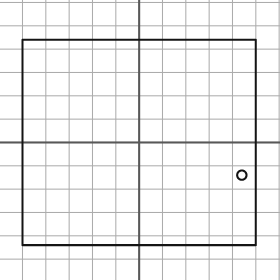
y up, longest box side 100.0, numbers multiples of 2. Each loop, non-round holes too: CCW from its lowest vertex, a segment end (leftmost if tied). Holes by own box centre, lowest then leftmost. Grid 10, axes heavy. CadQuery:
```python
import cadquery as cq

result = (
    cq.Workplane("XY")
    .moveTo(-50.0, -44.0)
    .lineTo(50.0, -44.0)
    .lineTo(50.0, 44.0)
    .lineTo(-50.0, 44.0)
    .close()
    .moveTo(44.0, -14.0)
    .circle(2.0)
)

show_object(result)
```